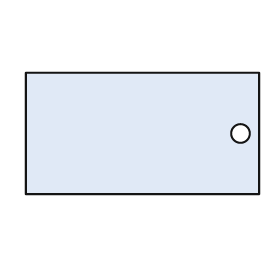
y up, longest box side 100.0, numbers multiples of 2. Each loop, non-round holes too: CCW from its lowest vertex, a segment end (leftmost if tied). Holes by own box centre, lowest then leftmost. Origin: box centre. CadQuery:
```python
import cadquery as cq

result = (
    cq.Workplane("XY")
    .moveTo(-50.0, -26.0)
    .lineTo(50.0, -26.0)
    .lineTo(50.0, 26.0)
    .lineTo(-50.0, 26.0)
    .close()
    .moveTo(42.0, 0.0)
    .circle(4.0)
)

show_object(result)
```